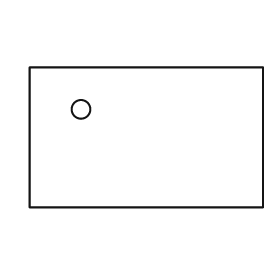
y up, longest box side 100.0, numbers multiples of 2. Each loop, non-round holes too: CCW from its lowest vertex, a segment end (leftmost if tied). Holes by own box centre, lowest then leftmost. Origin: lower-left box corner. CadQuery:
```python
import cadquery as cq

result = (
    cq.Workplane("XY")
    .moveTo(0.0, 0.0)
    .lineTo(100.0, 0.0)
    .lineTo(100.0, 60.0)
    .lineTo(0.0, 60.0)
    .close()
    .moveTo(22.0, 42.0)
    .circle(4.0)
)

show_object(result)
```